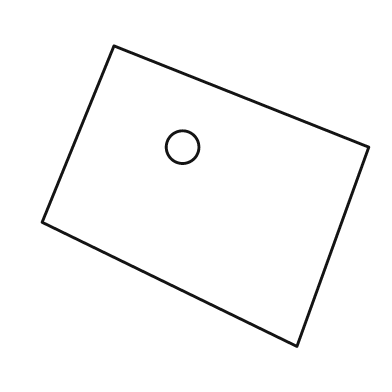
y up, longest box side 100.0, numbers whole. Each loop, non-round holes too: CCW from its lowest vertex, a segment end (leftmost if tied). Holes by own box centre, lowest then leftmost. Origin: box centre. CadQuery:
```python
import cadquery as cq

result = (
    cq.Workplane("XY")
    .moveTo(28.0, -46.0)
    .lineTo(50.0, 15.0)
    .lineTo(-28.0, 46.0)
    .lineTo(-50.0, -8.0)
    .close()
    .moveTo(-7.0, 15.0)
    .circle(5.0)
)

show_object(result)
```